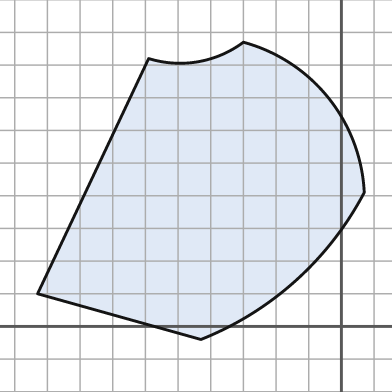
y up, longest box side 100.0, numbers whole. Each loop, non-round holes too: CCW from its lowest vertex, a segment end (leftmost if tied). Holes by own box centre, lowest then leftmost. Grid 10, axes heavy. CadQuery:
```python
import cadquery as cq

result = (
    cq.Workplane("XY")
    .moveTo(-43.0, -4.0)
    .threePointArc((-14.0, 14.0), (7.0, 41.0))
    .threePointArc((-4.0, 70.0), (-30.0, 87.0))
    .threePointArc((-44.0, 81.0), (-59.0, 82.0))
    .lineTo(-93.0, 10.0)
    .close()
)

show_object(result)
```